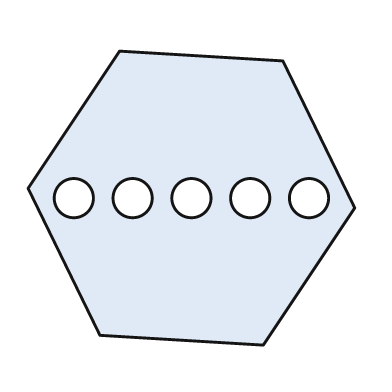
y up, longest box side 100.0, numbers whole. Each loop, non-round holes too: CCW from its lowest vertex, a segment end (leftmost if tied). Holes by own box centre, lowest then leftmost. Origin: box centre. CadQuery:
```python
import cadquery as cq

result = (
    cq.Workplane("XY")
    .moveTo(22.0, -45.0)
    .lineTo(50.0, -3.0)
    .lineTo(28.0, 42.0)
    .lineTo(-22.0, 45.0)
    .lineTo(-50.0, 3.0)
    .lineTo(-28.0, -42.0)
    .close()
    .moveTo(-36.0, 0.0)
    .circle(6.0)
    .moveTo(-18.0, 0.0)
    .circle(6.0)
    .moveTo(0.0, 0.0)
    .circle(6.0)
    .moveTo(18.0, 0.0)
    .circle(6.0)
    .moveTo(36.0, 0.0)
    .circle(6.0)
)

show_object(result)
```